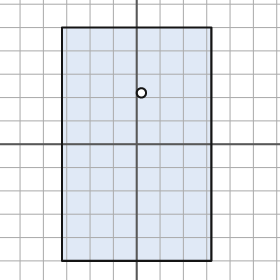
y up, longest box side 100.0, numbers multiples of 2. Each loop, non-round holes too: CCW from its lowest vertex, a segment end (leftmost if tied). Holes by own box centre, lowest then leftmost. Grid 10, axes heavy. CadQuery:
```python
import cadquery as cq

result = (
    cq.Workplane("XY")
    .moveTo(-32.0, -50.0)
    .lineTo(32.0, -50.0)
    .lineTo(32.0, 50.0)
    .lineTo(-32.0, 50.0)
    .close()
    .moveTo(2.0, 22.0)
    .circle(2.0)
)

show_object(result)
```